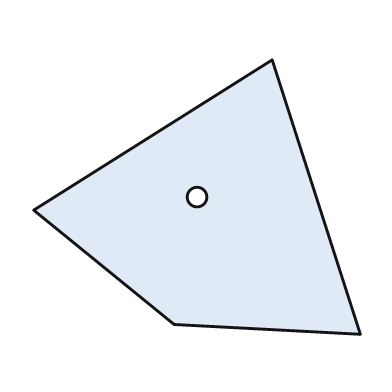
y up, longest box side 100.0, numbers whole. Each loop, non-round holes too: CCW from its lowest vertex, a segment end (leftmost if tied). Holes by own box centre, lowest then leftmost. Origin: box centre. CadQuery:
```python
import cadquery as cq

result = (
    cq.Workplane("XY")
    .moveTo(50.0, -42.0)
    .lineTo(23.0, 42.0)
    .lineTo(-50.0, -4.0)
    .lineTo(-7.0, -39.0)
    .close()
    .moveTo(0.0, 0.0)
    .circle(3.0)
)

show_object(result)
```